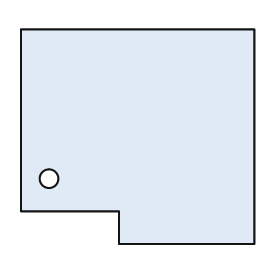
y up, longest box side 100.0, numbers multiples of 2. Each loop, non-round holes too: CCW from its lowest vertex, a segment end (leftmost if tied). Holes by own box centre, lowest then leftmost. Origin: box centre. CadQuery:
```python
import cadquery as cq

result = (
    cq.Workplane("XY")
    .moveTo(-8.0, -46.0)
    .lineTo(50.0, -46.0)
    .lineTo(50.0, 46.0)
    .lineTo(-50.0, 46.0)
    .lineTo(-50.0, -32.0)
    .lineTo(-8.0, -32.0)
    .close()
    .moveTo(-38.0, -18.0)
    .circle(4.0)
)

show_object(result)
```